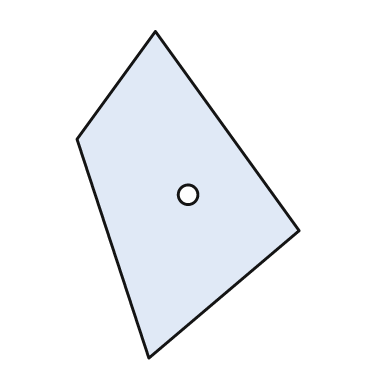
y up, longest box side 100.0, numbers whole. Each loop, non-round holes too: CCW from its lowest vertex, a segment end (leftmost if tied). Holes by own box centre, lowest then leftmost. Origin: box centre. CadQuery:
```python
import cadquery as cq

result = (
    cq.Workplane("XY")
    .moveTo(-12.0, -50.0)
    .lineTo(34.0, -11.0)
    .lineTo(-10.0, 50.0)
    .lineTo(-34.0, 17.0)
    .close()
    .moveTo(0.0, 0.0)
    .circle(3.0)
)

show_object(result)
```